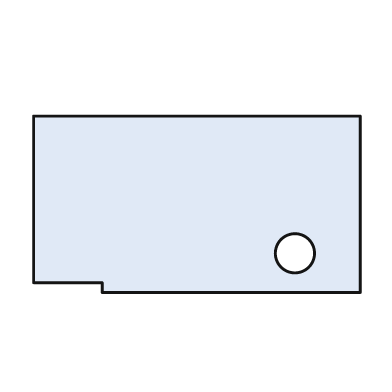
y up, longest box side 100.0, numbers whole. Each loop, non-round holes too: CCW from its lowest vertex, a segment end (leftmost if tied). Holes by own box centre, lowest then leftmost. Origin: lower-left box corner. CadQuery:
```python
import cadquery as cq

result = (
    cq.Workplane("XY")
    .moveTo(21.0, 0.0)
    .lineTo(100.0, 0.0)
    .lineTo(100.0, 54.0)
    .lineTo(0.0, 54.0)
    .lineTo(0.0, 3.0)
    .lineTo(21.0, 3.0)
    .close()
    .moveTo(80.0, 12.0)
    .circle(6.0)
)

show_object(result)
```